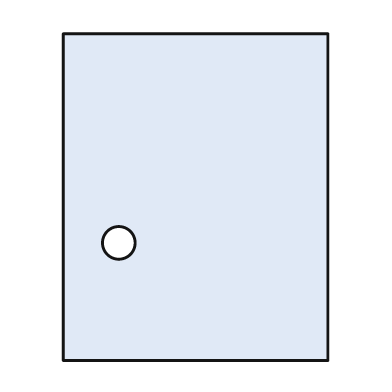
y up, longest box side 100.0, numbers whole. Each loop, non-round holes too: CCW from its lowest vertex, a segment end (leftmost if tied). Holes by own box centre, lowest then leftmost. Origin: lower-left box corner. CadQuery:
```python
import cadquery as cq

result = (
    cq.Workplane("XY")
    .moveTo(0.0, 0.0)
    .lineTo(81.0, 0.0)
    .lineTo(81.0, 100.0)
    .lineTo(0.0, 100.0)
    .close()
    .moveTo(17.0, 36.0)
    .circle(5.0)
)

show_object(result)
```